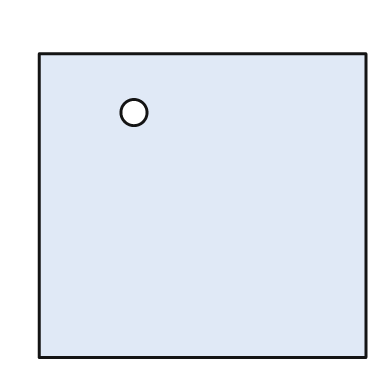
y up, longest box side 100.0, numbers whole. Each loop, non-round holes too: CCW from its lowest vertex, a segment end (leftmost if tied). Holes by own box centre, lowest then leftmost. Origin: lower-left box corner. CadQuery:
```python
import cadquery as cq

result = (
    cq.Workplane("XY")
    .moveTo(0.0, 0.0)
    .lineTo(100.0, 0.0)
    .lineTo(100.0, 93.0)
    .lineTo(0.0, 93.0)
    .close()
    .moveTo(29.0, 75.0)
    .circle(4.0)
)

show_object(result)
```